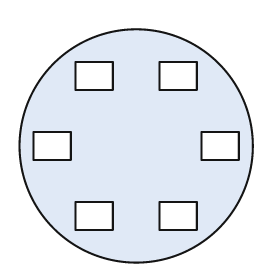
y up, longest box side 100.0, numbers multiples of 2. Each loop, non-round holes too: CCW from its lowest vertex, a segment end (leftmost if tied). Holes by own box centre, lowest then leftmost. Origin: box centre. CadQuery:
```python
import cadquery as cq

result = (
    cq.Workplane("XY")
    .moveTo(0.0, 0.0)
    .circle(50.0)
    .moveTo(-26.0, -36.0)
    .lineTo(-10.0, -36.0)
    .lineTo(-10.0, -24.0)
    .lineTo(-26.0, -24.0)
    .close()
    .moveTo(10.0, -36.0)
    .lineTo(26.0, -36.0)
    .lineTo(26.0, -24.0)
    .lineTo(10.0, -24.0)
    .close()
    .moveTo(-44.0, -6.0)
    .lineTo(-28.0, -6.0)
    .lineTo(-28.0, 6.0)
    .lineTo(-44.0, 6.0)
    .close()
    .moveTo(28.0, -6.0)
    .lineTo(44.0, -6.0)
    .lineTo(44.0, 6.0)
    .lineTo(28.0, 6.0)
    .close()
    .moveTo(-26.0, 24.0)
    .lineTo(-10.0, 24.0)
    .lineTo(-10.0, 36.0)
    .lineTo(-26.0, 36.0)
    .close()
    .moveTo(10.0, 24.0)
    .lineTo(26.0, 24.0)
    .lineTo(26.0, 36.0)
    .lineTo(10.0, 36.0)
    .close()
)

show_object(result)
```